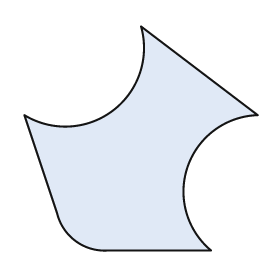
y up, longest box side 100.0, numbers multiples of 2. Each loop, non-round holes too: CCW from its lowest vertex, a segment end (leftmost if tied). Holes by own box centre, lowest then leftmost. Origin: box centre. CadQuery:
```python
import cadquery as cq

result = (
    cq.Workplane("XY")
    .moveTo(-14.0, -48.0)
    .lineTo(30.0, -48.0)
    .threePointArc((20.0, -12.0), (50.0, 10.0))
    .lineTo(0.0, 48.0)
    .threePointArc((-12.0, 12.0), (-50.0, 10.0))
    .lineTo(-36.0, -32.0)
    .threePointArc((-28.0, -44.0), (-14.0, -48.0))
    .close()
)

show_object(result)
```